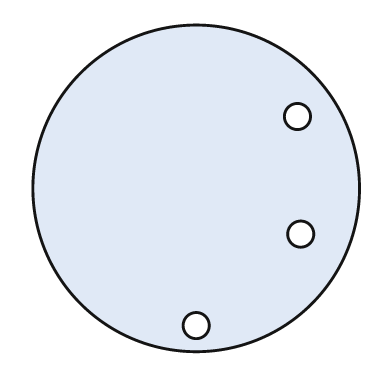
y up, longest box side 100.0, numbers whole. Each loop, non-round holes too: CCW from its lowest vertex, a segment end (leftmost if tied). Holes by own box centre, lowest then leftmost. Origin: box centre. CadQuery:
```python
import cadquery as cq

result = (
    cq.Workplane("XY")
    .moveTo(0.0, 0.0)
    .circle(50.0)
    .moveTo(0.0, -42.0)
    .circle(4.0)
    .moveTo(32.0, -14.0)
    .circle(4.0)
    .moveTo(31.0, 22.0)
    .circle(4.0)
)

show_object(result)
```